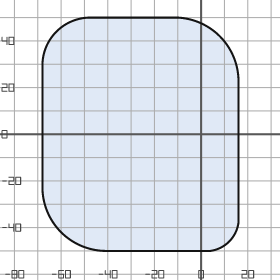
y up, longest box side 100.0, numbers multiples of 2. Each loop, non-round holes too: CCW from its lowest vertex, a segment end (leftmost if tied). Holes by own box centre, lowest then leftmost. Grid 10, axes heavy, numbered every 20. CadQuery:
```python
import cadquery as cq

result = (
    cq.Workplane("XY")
    .moveTo(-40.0, -50.0)
    .lineTo(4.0, -50.0)
    .threePointArc((12.0, -46.0), (16.0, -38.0))
    .lineTo(16.0, 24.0)
    .threePointArc((8.0, 42.0), (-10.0, 50.0))
    .lineTo(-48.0, 50.0)
    .threePointArc((-62.0, 44.0), (-68.0, 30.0))
    .lineTo(-68.0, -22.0)
    .threePointArc((-60.0, -42.0), (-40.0, -50.0))
    .close()
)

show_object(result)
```